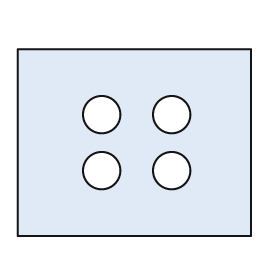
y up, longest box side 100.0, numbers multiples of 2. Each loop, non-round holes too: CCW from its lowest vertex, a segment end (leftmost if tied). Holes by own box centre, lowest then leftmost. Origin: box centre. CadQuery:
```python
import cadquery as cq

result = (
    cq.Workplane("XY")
    .moveTo(-50.0, -40.0)
    .lineTo(50.0, -40.0)
    .lineTo(50.0, 40.0)
    .lineTo(-50.0, 40.0)
    .close()
    .moveTo(-14.0, -12.0)
    .circle(8.0)
    .moveTo(16.0, -12.0)
    .circle(8.0)
    .moveTo(-14.0, 12.0)
    .circle(8.0)
    .moveTo(16.0, 12.0)
    .circle(8.0)
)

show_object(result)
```